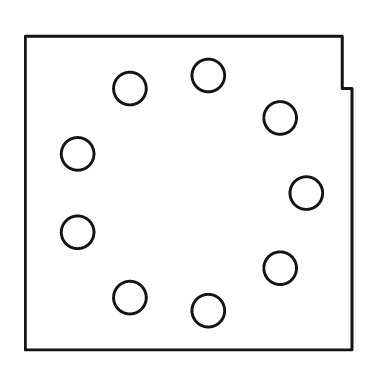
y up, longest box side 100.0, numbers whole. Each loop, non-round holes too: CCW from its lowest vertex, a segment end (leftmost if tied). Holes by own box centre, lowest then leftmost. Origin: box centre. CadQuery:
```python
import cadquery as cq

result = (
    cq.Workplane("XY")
    .moveTo(-50.0, -48.0)
    .lineTo(50.0, -48.0)
    .lineTo(50.0, 32.0)
    .lineTo(47.0, 32.0)
    .lineTo(47.0, 48.0)
    .lineTo(-50.0, 48.0)
    .close()
    .moveTo(6.0, -36.0)
    .circle(5.0)
    .moveTo(-18.0, -32.0)
    .circle(5.0)
    .moveTo(28.0, -23.0)
    .circle(5.0)
    .moveTo(-34.0, -12.0)
    .circle(5.0)
    .moveTo(36.0, 0.0)
    .circle(5.0)
    .moveTo(-34.0, 12.0)
    .circle(5.0)
    .moveTo(28.0, 23.0)
    .circle(5.0)
    .moveTo(-18.0, 32.0)
    .circle(5.0)
    .moveTo(6.0, 36.0)
    .circle(5.0)
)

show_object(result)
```